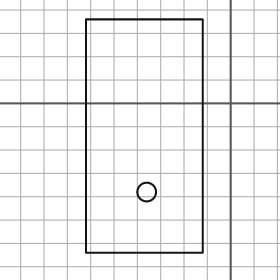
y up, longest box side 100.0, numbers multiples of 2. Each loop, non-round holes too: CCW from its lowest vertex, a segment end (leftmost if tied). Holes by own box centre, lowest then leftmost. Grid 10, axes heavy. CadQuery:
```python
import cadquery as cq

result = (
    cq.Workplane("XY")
    .moveTo(-62.0, -64.0)
    .lineTo(-12.0, -64.0)
    .lineTo(-12.0, 36.0)
    .lineTo(-62.0, 36.0)
    .close()
    .moveTo(-36.0, -38.0)
    .circle(4.0)
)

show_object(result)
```